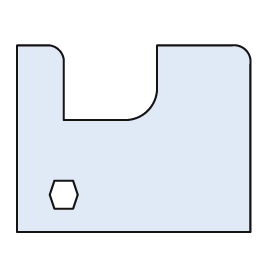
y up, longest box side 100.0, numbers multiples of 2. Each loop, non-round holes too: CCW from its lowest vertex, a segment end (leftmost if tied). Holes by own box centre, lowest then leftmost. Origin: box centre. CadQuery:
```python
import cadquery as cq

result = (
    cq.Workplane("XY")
    .moveTo(-50.0, -40.0)
    .lineTo(50.0, -40.0)
    .lineTo(50.0, 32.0)
    .threePointArc((48.0, 38.0), (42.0, 40.0))
    .lineTo(10.0, 40.0)
    .lineTo(10.0, 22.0)
    .threePointArc((6.0, 12.0), (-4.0, 8.0))
    .lineTo(-30.0, 8.0)
    .lineTo(-30.0, 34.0)
    .threePointArc((-32.0, 38.0), (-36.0, 40.0))
    .lineTo(-50.0, 40.0)
    .close()
    .moveTo(-34.0, -30.0)
    .lineTo(-26.0, -30.0)
    .lineTo(-24.0, -24.0)
    .lineTo(-26.0, -18.0)
    .lineTo(-34.0, -18.0)
    .lineTo(-36.0, -24.0)
    .close()
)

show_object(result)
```